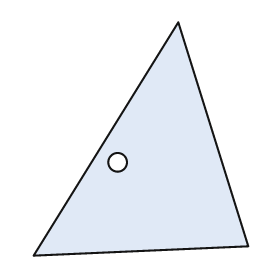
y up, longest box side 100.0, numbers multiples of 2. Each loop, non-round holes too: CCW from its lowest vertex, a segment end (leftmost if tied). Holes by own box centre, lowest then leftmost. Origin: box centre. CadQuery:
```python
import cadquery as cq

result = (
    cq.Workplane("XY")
    .moveTo(-46.0, -50.0)
    .lineTo(46.0, -46.0)
    .lineTo(16.0, 50.0)
    .close()
    .moveTo(-10.0, -10.0)
    .circle(4.0)
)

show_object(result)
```